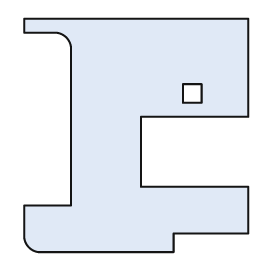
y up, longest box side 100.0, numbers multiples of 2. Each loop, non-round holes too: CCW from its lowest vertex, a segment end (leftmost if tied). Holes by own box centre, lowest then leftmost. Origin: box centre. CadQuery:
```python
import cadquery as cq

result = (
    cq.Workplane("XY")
    .moveTo(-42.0, -50.0)
    .lineTo(16.0, -50.0)
    .lineTo(16.0, -42.0)
    .lineTo(48.0, -42.0)
    .lineTo(48.0, -22.0)
    .lineTo(2.0, -22.0)
    .lineTo(2.0, 8.0)
    .lineTo(48.0, 8.0)
    .lineTo(48.0, 50.0)
    .lineTo(-48.0, 50.0)
    .lineTo(-48.0, 44.0)
    .lineTo(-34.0, 44.0)
    .threePointArc((-30.0, 42.0), (-28.0, 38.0))
    .lineTo(-28.0, -30.0)
    .lineTo(-48.0, -30.0)
    .lineTo(-48.0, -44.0)
    .threePointArc((-46.0, -48.0), (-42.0, -50.0))
    .close()
    .moveTo(20.0, 14.0)
    .lineTo(28.0, 14.0)
    .lineTo(28.0, 22.0)
    .lineTo(20.0, 22.0)
    .close()
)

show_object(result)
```